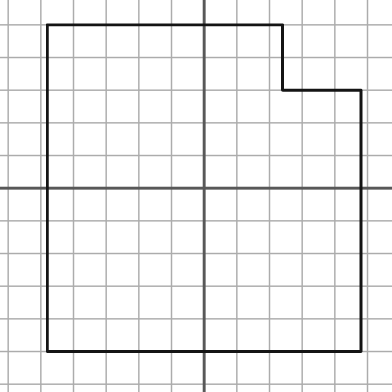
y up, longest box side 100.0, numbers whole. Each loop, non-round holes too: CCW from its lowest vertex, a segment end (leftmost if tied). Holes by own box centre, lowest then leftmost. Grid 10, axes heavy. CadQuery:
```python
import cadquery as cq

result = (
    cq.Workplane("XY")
    .moveTo(-48.0, -50.0)
    .lineTo(48.0, -50.0)
    .lineTo(48.0, 30.0)
    .lineTo(24.0, 30.0)
    .lineTo(24.0, 50.0)
    .lineTo(-48.0, 50.0)
    .close()
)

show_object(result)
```